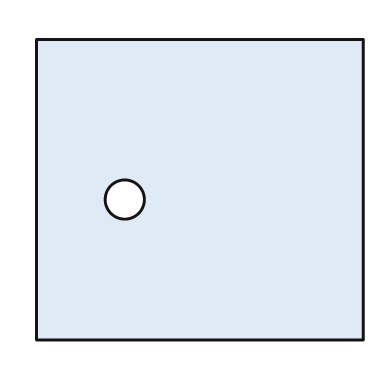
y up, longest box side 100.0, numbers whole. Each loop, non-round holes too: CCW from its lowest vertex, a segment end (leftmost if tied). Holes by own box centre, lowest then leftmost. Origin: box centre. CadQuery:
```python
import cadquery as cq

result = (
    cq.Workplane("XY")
    .moveTo(-50.0, -46.0)
    .lineTo(50.0, -46.0)
    .lineTo(50.0, 46.0)
    .lineTo(-50.0, 46.0)
    .close()
    .moveTo(-23.0, -3.0)
    .circle(6.0)
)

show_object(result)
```